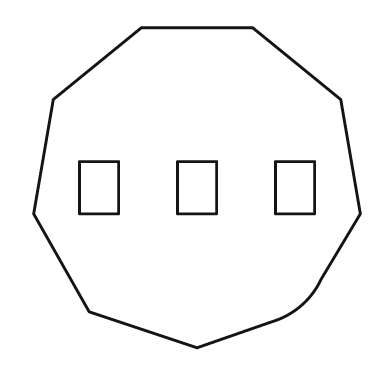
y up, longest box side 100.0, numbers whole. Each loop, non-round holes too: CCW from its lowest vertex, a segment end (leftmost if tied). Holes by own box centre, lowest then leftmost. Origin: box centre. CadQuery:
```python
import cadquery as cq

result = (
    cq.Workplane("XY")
    .moveTo(0.0, -49.0)
    .lineTo(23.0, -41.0)
    .threePointArc((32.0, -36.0), (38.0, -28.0))
    .lineTo(50.0, -8.0)
    .lineTo(44.0, 27.0)
    .lineTo(17.0, 49.0)
    .lineTo(-17.0, 49.0)
    .lineTo(-44.0, 27.0)
    .lineTo(-50.0, -8.0)
    .lineTo(-33.0, -38.0)
    .close()
    .moveTo(-36.0, -8.0)
    .lineTo(-24.0, -8.0)
    .lineTo(-24.0, 8.0)
    .lineTo(-36.0, 8.0)
    .close()
    .moveTo(-6.0, -8.0)
    .lineTo(6.0, -8.0)
    .lineTo(6.0, 8.0)
    .lineTo(-6.0, 8.0)
    .close()
    .moveTo(24.0, -8.0)
    .lineTo(36.0, -8.0)
    .lineTo(36.0, 8.0)
    .lineTo(24.0, 8.0)
    .close()
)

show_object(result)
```